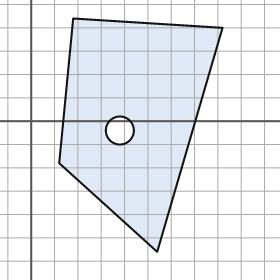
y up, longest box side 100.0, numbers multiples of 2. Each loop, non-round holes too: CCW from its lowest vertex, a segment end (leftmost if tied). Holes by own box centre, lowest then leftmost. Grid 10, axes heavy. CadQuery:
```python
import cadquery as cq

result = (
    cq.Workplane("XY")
    .moveTo(54.0, -56.0)
    .lineTo(82.0, 40.0)
    .lineTo(18.0, 44.0)
    .lineTo(12.0, -18.0)
    .close()
    .moveTo(38.0, -4.0)
    .circle(6.0)
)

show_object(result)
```